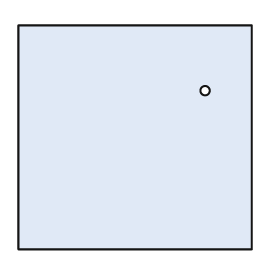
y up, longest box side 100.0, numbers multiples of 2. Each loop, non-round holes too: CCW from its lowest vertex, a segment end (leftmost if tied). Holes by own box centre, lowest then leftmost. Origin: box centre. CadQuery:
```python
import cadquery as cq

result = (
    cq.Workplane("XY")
    .moveTo(-50.0, -48.0)
    .lineTo(50.0, -48.0)
    .lineTo(50.0, 48.0)
    .lineTo(-50.0, 48.0)
    .close()
    .moveTo(30.0, 20.0)
    .circle(2.0)
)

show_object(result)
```